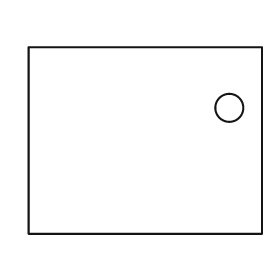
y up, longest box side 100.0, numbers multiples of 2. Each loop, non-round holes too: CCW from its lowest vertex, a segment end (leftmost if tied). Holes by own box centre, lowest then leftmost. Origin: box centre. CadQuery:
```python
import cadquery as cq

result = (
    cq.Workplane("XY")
    .moveTo(-50.0, -40.0)
    .lineTo(50.0, -40.0)
    .lineTo(50.0, 40.0)
    .lineTo(-50.0, 40.0)
    .close()
    .moveTo(36.0, 14.0)
    .circle(6.0)
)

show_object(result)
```